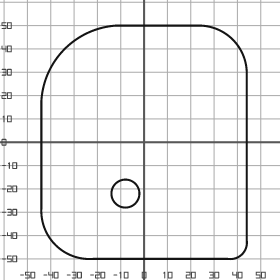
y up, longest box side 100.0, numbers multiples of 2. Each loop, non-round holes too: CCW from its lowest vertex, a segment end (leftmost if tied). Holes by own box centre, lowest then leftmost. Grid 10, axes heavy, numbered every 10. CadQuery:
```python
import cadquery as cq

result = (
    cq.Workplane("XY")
    .moveTo(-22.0, -50.0)
    .lineTo(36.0, -50.0)
    .threePointArc((42.0, -48.0), (44.0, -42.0))
    .lineTo(44.0, 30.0)
    .threePointArc((38.0, 44.0), (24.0, 50.0))
    .lineTo(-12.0, 50.0)
    .threePointArc((-34.0, 40.0), (-44.0, 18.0))
    .lineTo(-44.0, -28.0)
    .threePointArc((-38.0, -44.0), (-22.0, -50.0))
    .close()
    .moveTo(-8.0, -22.0)
    .circle(6.0)
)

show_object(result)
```